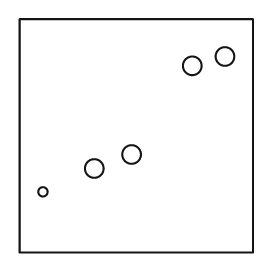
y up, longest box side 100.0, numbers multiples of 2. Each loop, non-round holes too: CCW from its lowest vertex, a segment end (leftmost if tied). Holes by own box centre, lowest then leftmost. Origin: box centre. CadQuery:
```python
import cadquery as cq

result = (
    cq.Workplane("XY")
    .moveTo(-50.0, -50.0)
    .lineTo(50.0, -50.0)
    .lineTo(50.0, 50.0)
    .lineTo(-50.0, 50.0)
    .close()
    .moveTo(-40.0, -24.0)
    .circle(2.0)
    .moveTo(-18.0, -14.0)
    .circle(4.0)
    .moveTo(-2.0, -8.0)
    .circle(4.0)
    .moveTo(24.0, 30.0)
    .circle(4.0)
    .moveTo(38.0, 34.0)
    .circle(4.0)
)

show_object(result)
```